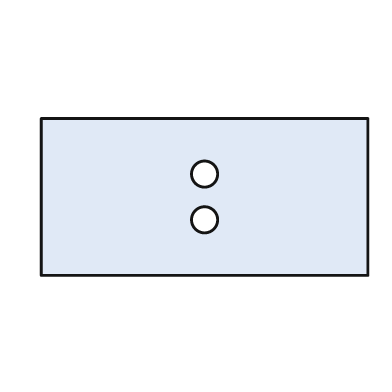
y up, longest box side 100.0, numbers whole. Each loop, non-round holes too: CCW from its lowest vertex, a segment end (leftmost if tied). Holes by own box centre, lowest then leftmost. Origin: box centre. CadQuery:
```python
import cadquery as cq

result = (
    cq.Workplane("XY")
    .moveTo(-50.0, -24.0)
    .lineTo(50.0, -24.0)
    .lineTo(50.0, 24.0)
    .lineTo(-50.0, 24.0)
    .close()
    .moveTo(0.0, -7.0)
    .circle(4.0)
    .moveTo(0.0, 7.0)
    .circle(4.0)
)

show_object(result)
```